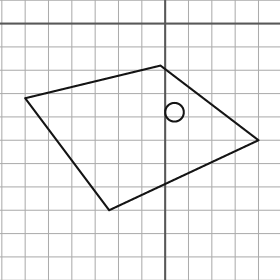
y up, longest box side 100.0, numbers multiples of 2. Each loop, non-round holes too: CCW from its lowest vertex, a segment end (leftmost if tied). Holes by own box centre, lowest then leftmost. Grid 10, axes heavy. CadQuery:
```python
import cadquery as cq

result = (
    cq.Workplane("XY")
    .moveTo(-24.0, -80.0)
    .lineTo(40.0, -50.0)
    .lineTo(-2.0, -18.0)
    .lineTo(-60.0, -32.0)
    .close()
    .moveTo(4.0, -38.0)
    .circle(4.0)
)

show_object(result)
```